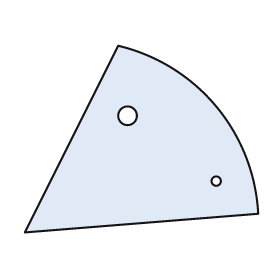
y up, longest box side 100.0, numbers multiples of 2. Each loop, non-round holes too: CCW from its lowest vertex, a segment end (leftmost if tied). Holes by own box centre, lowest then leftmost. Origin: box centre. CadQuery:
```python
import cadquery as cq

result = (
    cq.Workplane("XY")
    .moveTo(-50.0, -40.0)
    .lineTo(50.0, -32.0)
    .threePointArc((32.0, 14.0), (-10.0, 40.0))
    .close()
    .moveTo(32.0, -18.0)
    .circle(2.0)
    .moveTo(-6.0, 10.0)
    .circle(4.0)
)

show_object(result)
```